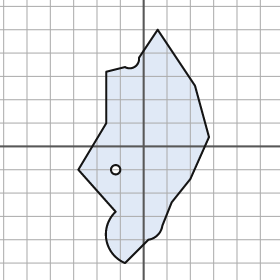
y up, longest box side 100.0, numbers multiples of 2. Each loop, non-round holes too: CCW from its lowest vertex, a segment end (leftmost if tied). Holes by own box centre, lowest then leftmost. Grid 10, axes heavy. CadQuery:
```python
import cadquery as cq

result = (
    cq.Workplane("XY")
    .moveTo(-8.0, -50.0)
    .lineTo(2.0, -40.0)
    .threePointArc((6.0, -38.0), (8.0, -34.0))
    .lineTo(12.0, -24.0)
    .lineTo(20.0, -14.0)
    .lineTo(28.0, 4.0)
    .lineTo(22.0, 26.0)
    .lineTo(6.0, 50.0)
    .lineTo(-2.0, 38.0)
    .threePointArc((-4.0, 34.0), (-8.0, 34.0))
    .lineTo(-16.0, 32.0)
    .lineTo(-16.0, 10.0)
    .lineTo(-28.0, -10.0)
    .lineTo(-12.0, -28.0)
    .threePointArc((-16.0, -40.0), (-8.0, -50.0))
    .close()
    .moveTo(-12.0, -10.0)
    .circle(2.0)
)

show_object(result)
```